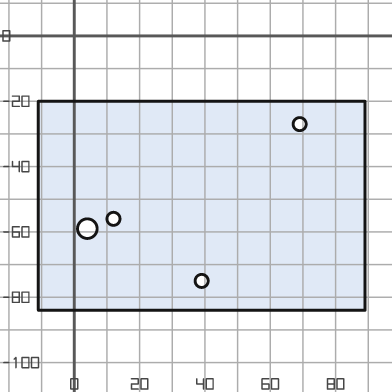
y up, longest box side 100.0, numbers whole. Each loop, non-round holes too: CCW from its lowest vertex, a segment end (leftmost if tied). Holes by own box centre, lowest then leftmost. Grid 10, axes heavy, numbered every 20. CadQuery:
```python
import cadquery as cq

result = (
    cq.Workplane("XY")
    .moveTo(-11.0, -84.0)
    .lineTo(89.0, -84.0)
    .lineTo(89.0, -20.0)
    .lineTo(-11.0, -20.0)
    .close()
    .moveTo(39.0, -75.0)
    .circle(2.0)
    .moveTo(4.0, -59.0)
    .circle(3.0)
    .moveTo(12.0, -56.0)
    .circle(2.0)
    .moveTo(69.0, -27.0)
    .circle(2.0)
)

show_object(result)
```